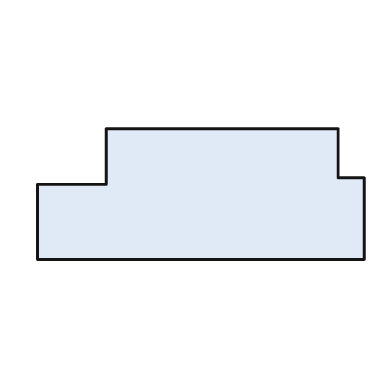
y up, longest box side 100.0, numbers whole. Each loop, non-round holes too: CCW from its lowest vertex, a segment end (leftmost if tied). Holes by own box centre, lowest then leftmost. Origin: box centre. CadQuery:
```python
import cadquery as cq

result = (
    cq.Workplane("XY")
    .moveTo(-50.0, -20.0)
    .lineTo(50.0, -20.0)
    .lineTo(50.0, 5.0)
    .lineTo(42.0, 5.0)
    .lineTo(42.0, 20.0)
    .lineTo(-29.0, 20.0)
    .lineTo(-29.0, 3.0)
    .lineTo(-50.0, 3.0)
    .close()
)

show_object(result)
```